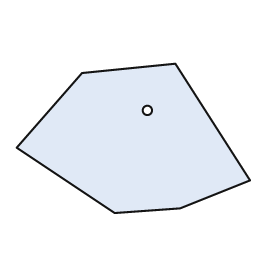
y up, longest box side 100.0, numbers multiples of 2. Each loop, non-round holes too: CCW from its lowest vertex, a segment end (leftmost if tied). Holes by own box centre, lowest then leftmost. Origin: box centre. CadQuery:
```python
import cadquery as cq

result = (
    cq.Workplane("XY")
    .moveTo(-8.0, -32.0)
    .lineTo(20.0, -30.0)
    .lineTo(50.0, -18.0)
    .lineTo(18.0, 32.0)
    .lineTo(-22.0, 28.0)
    .lineTo(-50.0, -4.0)
    .close()
    .moveTo(6.0, 12.0)
    .circle(2.0)
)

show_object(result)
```